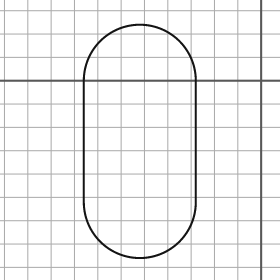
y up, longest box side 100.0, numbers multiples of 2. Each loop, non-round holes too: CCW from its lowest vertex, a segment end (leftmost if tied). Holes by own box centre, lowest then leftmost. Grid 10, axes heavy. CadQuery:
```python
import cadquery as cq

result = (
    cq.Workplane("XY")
    .moveTo(-76.0, -52.0)
    .threePointArc((-52.0, -76.0), (-28.0, -52.0))
    .lineTo(-28.0, 0.0)
    .threePointArc((-52.0, 24.0), (-76.0, 0.0))
    .close()
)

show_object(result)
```